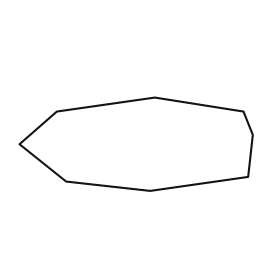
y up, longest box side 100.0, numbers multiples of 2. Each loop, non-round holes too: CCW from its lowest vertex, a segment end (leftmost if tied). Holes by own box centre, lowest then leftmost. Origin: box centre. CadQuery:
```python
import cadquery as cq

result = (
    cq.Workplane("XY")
    .moveTo(6.0, -20.0)
    .lineTo(48.0, -14.0)
    .lineTo(50.0, 4.0)
    .lineTo(46.0, 14.0)
    .lineTo(8.0, 20.0)
    .lineTo(-34.0, 14.0)
    .lineTo(-50.0, 0.0)
    .lineTo(-30.0, -16.0)
    .close()
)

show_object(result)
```